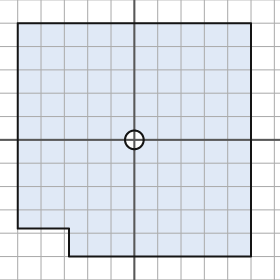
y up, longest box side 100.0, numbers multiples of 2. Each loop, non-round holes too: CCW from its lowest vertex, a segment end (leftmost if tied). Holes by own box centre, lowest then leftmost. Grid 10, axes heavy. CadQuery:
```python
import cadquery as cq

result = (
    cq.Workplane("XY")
    .moveTo(-28.0, -50.0)
    .lineTo(50.0, -50.0)
    .lineTo(50.0, 50.0)
    .lineTo(-50.0, 50.0)
    .lineTo(-50.0, -38.0)
    .lineTo(-28.0, -38.0)
    .close()
    .moveTo(0.0, 0.0)
    .circle(4.0)
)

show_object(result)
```